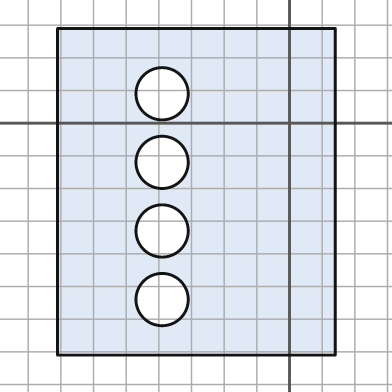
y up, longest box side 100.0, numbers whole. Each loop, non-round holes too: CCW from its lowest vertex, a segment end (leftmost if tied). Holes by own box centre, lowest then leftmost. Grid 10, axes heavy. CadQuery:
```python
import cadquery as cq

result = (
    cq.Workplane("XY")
    .moveTo(-71.0, -71.0)
    .lineTo(14.0, -71.0)
    .lineTo(14.0, 29.0)
    .lineTo(-71.0, 29.0)
    .close()
    .moveTo(-39.0, -54.0)
    .circle(8.0)
    .moveTo(-39.0, -33.0)
    .circle(8.0)
    .moveTo(-39.0, -12.0)
    .circle(8.0)
    .moveTo(-39.0, 9.0)
    .circle(8.0)
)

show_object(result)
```